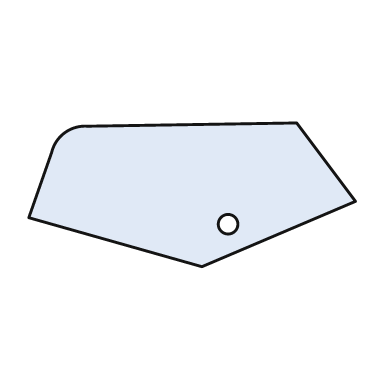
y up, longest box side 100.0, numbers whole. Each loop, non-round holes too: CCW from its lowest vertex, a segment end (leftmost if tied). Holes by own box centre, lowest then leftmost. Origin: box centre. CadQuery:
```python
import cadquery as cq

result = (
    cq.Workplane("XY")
    .moveTo(3.0, -22.0)
    .lineTo(50.0, -2.0)
    .lineTo(32.0, 22.0)
    .lineTo(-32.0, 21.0)
    .threePointArc((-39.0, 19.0), (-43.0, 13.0))
    .lineTo(-50.0, -7.0)
    .close()
    .moveTo(11.0, -9.0)
    .circle(3.0)
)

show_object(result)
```